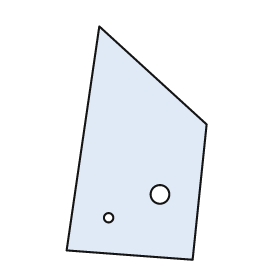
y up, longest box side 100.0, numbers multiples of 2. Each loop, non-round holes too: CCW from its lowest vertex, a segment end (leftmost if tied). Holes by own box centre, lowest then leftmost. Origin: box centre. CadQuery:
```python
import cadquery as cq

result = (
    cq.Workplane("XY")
    .moveTo(24.0, -50.0)
    .lineTo(30.0, 8.0)
    .lineTo(-16.0, 50.0)
    .lineTo(-30.0, -46.0)
    .close()
    .moveTo(-12.0, -32.0)
    .circle(2.0)
    .moveTo(10.0, -22.0)
    .circle(4.0)
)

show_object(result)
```